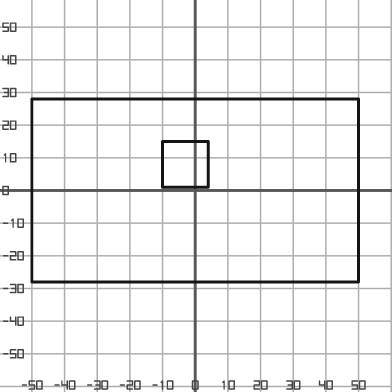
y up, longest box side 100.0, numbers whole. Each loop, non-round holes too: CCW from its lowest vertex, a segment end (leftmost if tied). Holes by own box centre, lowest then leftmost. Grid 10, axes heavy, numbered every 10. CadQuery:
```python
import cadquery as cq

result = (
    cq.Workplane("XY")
    .moveTo(-50.0, -28.0)
    .lineTo(50.0, -28.0)
    .lineTo(50.0, 28.0)
    .lineTo(-50.0, 28.0)
    .close()
    .moveTo(-10.0, 1.0)
    .lineTo(4.0, 1.0)
    .lineTo(4.0, 15.0)
    .lineTo(-10.0, 15.0)
    .close()
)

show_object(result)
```